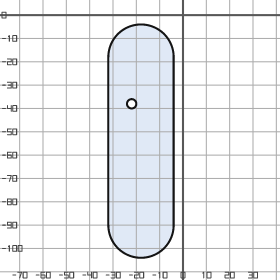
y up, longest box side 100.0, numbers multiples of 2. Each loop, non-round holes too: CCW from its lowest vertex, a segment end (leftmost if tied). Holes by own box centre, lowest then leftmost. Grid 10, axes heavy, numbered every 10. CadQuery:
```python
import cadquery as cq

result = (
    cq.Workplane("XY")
    .moveTo(-32.0, -90.0)
    .threePointArc((-18.0, -104.0), (-4.0, -90.0))
    .lineTo(-4.0, -18.0)
    .threePointArc((-18.0, -4.0), (-32.0, -18.0))
    .close()
    .moveTo(-22.0, -38.0)
    .circle(2.0)
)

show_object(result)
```